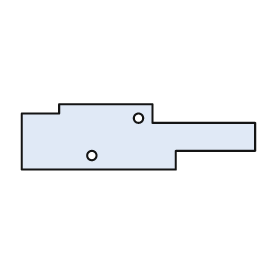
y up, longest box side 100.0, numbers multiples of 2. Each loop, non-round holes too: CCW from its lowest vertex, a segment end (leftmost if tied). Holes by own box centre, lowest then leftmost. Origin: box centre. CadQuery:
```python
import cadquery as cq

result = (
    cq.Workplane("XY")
    .moveTo(-50.0, -14.0)
    .lineTo(16.0, -14.0)
    .lineTo(16.0, -6.0)
    .lineTo(50.0, -6.0)
    .lineTo(50.0, 6.0)
    .lineTo(6.0, 6.0)
    .lineTo(6.0, 14.0)
    .lineTo(-34.0, 14.0)
    .lineTo(-34.0, 10.0)
    .lineTo(-50.0, 10.0)
    .close()
    .moveTo(-20.0, -8.0)
    .circle(2.0)
    .moveTo(0.0, 8.0)
    .circle(2.0)
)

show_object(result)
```